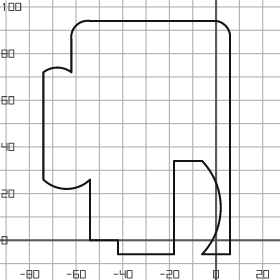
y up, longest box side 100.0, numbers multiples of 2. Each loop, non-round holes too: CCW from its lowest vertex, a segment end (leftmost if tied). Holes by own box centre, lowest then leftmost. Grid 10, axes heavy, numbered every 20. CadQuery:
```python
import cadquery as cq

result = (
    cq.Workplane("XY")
    .moveTo(-42.0, -6.0)
    .lineTo(-18.0, -6.0)
    .lineTo(-18.0, 34.0)
    .lineTo(-6.0, 34.0)
    .threePointArc((2.0, 14.0), (-6.0, -6.0))
    .lineTo(6.0, -6.0)
    .lineTo(6.0, 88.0)
    .threePointArc((4.0, 92.0), (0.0, 94.0))
    .lineTo(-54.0, 94.0)
    .threePointArc((-60.0, 92.0), (-62.0, 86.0))
    .lineTo(-62.0, 72.0)
    .threePointArc((-68.0, 74.0), (-74.0, 72.0))
    .lineTo(-74.0, 26.0)
    .threePointArc((-64.0, 22.0), (-54.0, 26.0))
    .lineTo(-54.0, 0.0)
    .lineTo(-42.0, 0.0)
    .close()
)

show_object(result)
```